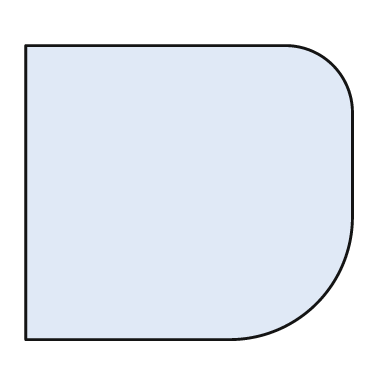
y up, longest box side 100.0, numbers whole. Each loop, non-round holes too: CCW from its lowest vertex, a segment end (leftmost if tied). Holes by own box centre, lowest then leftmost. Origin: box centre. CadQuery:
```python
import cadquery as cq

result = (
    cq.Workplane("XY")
    .moveTo(-50.0, -45.0)
    .lineTo(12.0, -45.0)
    .threePointArc((39.0, -34.0), (50.0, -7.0))
    .lineTo(50.0, 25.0)
    .threePointArc((44.0, 39.0), (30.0, 45.0))
    .lineTo(-50.0, 45.0)
    .close()
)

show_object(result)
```